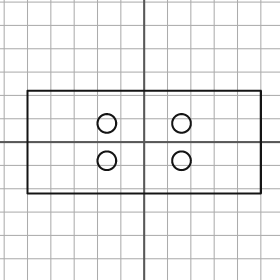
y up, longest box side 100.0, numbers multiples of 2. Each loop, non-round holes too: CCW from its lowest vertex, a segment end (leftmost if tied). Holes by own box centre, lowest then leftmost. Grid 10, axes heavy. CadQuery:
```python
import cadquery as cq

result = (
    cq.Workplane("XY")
    .moveTo(-50.0, -22.0)
    .lineTo(50.0, -22.0)
    .lineTo(50.0, 22.0)
    .lineTo(-50.0, 22.0)
    .close()
    .moveTo(-16.0, -8.0)
    .circle(4.0)
    .moveTo(16.0, -8.0)
    .circle(4.0)
    .moveTo(-16.0, 8.0)
    .circle(4.0)
    .moveTo(16.0, 8.0)
    .circle(4.0)
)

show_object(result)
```